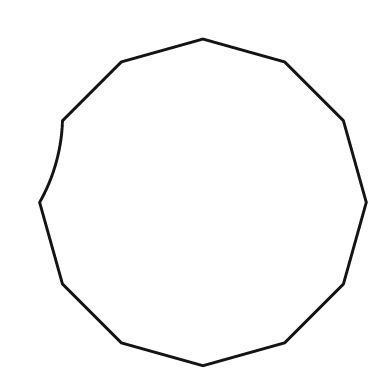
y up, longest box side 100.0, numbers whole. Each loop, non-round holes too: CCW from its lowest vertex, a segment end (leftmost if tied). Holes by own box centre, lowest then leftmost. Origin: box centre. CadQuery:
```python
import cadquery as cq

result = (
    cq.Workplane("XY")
    .moveTo(0.0, -50.0)
    .lineTo(25.0, -43.0)
    .lineTo(43.0, -25.0)
    .lineTo(50.0, 0.0)
    .lineTo(43.0, 25.0)
    .lineTo(25.0, 43.0)
    .lineTo(0.0, 50.0)
    .lineTo(-25.0, 43.0)
    .lineTo(-43.0, 25.0)
    .threePointArc((-45.0, 12.0), (-50.0, 0.0))
    .lineTo(-43.0, -25.0)
    .lineTo(-25.0, -43.0)
    .close()
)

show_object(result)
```